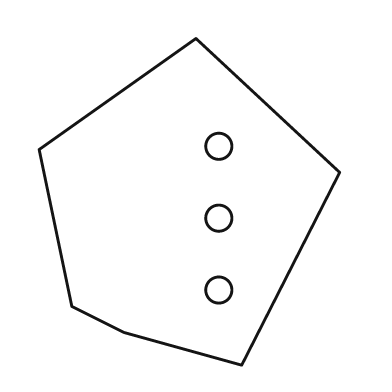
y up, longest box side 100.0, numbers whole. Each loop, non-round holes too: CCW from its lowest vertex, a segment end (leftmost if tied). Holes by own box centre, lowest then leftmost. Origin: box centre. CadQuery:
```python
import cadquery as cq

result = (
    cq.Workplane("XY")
    .moveTo(16.0, -50.0)
    .lineTo(46.0, 9.0)
    .lineTo(2.0, 50.0)
    .lineTo(-46.0, 16.0)
    .lineTo(-36.0, -32.0)
    .lineTo(-20.0, -40.0)
    .close()
    .moveTo(9.0, -27.0)
    .circle(4.0)
    .moveTo(9.0, -5.0)
    .circle(4.0)
    .moveTo(9.0, 17.0)
    .circle(4.0)
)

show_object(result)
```